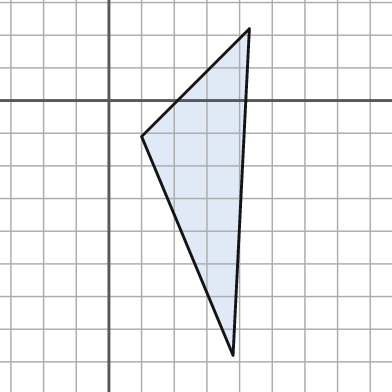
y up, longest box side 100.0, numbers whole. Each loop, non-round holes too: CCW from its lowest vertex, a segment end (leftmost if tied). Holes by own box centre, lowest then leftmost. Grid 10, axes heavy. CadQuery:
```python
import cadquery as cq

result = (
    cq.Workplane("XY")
    .moveTo(38.0, -78.0)
    .lineTo(43.0, 22.0)
    .lineTo(10.0, -11.0)
    .close()
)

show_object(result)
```